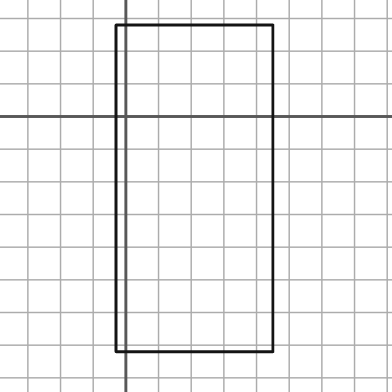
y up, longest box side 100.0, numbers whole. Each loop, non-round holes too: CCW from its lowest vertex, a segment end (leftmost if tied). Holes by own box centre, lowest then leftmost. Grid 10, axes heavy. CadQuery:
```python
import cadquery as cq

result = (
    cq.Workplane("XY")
    .moveTo(-3.0, -72.0)
    .lineTo(45.0, -72.0)
    .lineTo(45.0, 28.0)
    .lineTo(-3.0, 28.0)
    .close()
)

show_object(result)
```